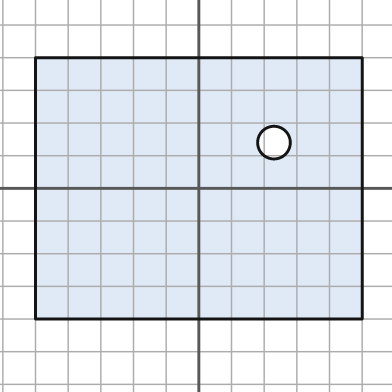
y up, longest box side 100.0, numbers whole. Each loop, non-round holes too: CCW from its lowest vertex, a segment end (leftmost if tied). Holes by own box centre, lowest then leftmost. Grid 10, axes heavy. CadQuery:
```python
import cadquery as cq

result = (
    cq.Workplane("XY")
    .moveTo(-50.0, -40.0)
    .lineTo(50.0, -40.0)
    .lineTo(50.0, 40.0)
    .lineTo(-50.0, 40.0)
    .close()
    .moveTo(23.0, 14.0)
    .circle(5.0)
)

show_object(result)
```